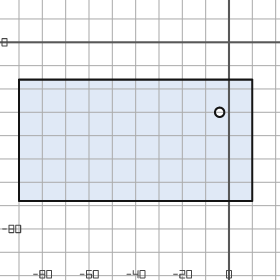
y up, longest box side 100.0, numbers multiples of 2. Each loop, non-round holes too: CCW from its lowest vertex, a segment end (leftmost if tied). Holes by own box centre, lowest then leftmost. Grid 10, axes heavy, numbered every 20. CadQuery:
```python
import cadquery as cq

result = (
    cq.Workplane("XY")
    .moveTo(-90.0, -68.0)
    .lineTo(10.0, -68.0)
    .lineTo(10.0, -16.0)
    .lineTo(-90.0, -16.0)
    .close()
    .moveTo(-4.0, -30.0)
    .circle(2.0)
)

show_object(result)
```